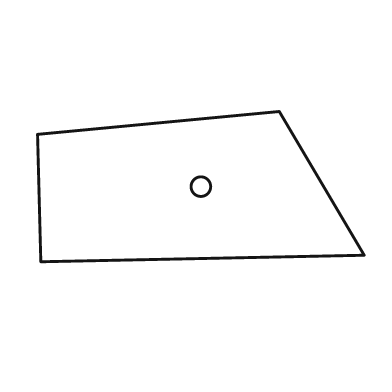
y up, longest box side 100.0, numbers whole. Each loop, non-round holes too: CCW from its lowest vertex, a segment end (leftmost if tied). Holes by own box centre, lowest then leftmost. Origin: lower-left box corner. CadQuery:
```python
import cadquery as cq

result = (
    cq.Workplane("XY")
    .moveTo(1.0, 0.0)
    .lineTo(100.0, 2.0)
    .lineTo(74.0, 46.0)
    .lineTo(0.0, 39.0)
    .close()
    .moveTo(50.0, 23.0)
    .circle(3.0)
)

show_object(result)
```